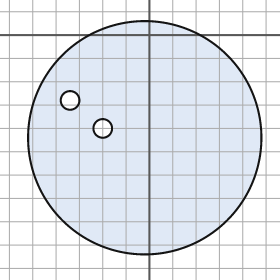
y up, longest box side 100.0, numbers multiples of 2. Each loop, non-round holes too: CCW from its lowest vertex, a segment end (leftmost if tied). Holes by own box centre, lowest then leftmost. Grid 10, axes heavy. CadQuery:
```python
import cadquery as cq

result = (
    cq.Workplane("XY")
    .moveTo(-2.0, -44.0)
    .circle(50.0)
    .moveTo(-20.0, -40.0)
    .circle(4.0)
    .moveTo(-34.0, -28.0)
    .circle(4.0)
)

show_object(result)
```